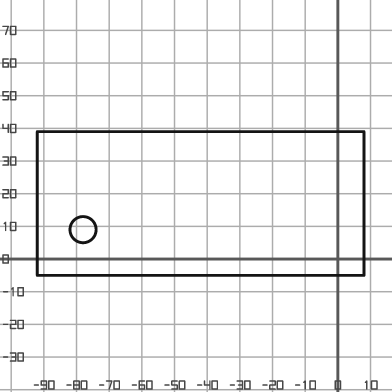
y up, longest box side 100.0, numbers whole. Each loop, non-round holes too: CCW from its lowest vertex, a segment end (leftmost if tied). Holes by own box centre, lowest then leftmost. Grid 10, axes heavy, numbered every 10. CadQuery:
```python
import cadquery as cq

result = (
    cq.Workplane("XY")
    .moveTo(-92.0, -5.0)
    .lineTo(8.0, -5.0)
    .lineTo(8.0, 39.0)
    .lineTo(-92.0, 39.0)
    .close()
    .moveTo(-78.0, 9.0)
    .circle(4.0)
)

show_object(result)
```